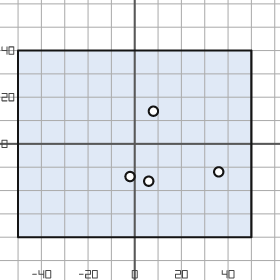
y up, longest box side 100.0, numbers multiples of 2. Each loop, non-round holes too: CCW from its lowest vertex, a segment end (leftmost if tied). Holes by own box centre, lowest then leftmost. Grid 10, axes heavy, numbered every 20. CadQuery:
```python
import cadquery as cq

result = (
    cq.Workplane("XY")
    .moveTo(-50.0, -40.0)
    .lineTo(50.0, -40.0)
    .lineTo(50.0, 40.0)
    .lineTo(-50.0, 40.0)
    .close()
    .moveTo(6.0, -16.0)
    .circle(2.0)
    .moveTo(-2.0, -14.0)
    .circle(2.0)
    .moveTo(36.0, -12.0)
    .circle(2.0)
    .moveTo(8.0, 14.0)
    .circle(2.0)
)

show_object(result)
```